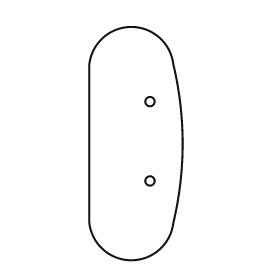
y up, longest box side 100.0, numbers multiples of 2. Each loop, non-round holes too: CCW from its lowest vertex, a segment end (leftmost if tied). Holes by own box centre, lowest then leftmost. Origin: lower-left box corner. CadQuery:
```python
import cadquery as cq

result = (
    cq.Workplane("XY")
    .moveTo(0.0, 16.0)
    .threePointArc((18.0, 0.0), (36.0, 16.0))
    .threePointArc((40.0, 50.0), (36.0, 84.0))
    .threePointArc((18.0, 100.0), (0.0, 84.0))
    .close()
    .moveTo(26.0, 34.0)
    .circle(2.0)
    .moveTo(26.0, 68.0)
    .circle(2.0)
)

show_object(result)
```